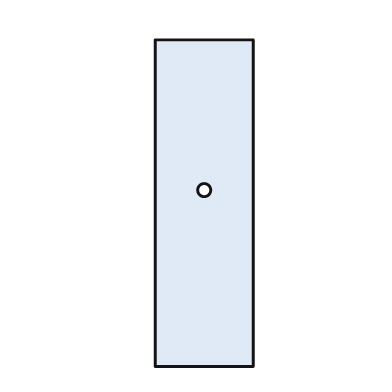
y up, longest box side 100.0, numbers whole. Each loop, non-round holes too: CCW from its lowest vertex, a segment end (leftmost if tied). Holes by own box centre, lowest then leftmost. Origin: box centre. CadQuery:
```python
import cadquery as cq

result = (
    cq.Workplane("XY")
    .moveTo(-15.0, -50.0)
    .lineTo(15.0, -50.0)
    .lineTo(15.0, 50.0)
    .lineTo(-15.0, 50.0)
    .close()
    .moveTo(0.0, 4.0)
    .circle(2.0)
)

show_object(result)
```